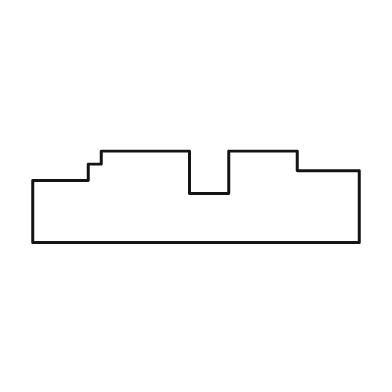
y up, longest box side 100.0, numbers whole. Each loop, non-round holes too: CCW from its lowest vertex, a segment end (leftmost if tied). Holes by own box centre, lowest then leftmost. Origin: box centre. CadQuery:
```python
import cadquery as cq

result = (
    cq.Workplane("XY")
    .moveTo(-50.0, -14.0)
    .lineTo(50.0, -14.0)
    .lineTo(50.0, 8.0)
    .lineTo(31.0, 8.0)
    .lineTo(31.0, 14.0)
    .lineTo(10.0, 14.0)
    .lineTo(10.0, 1.0)
    .lineTo(-2.0, 1.0)
    .lineTo(-2.0, 14.0)
    .lineTo(-29.0, 14.0)
    .lineTo(-29.0, 10.0)
    .lineTo(-33.0, 10.0)
    .lineTo(-33.0, 5.0)
    .lineTo(-50.0, 5.0)
    .close()
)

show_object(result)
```